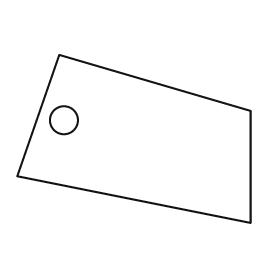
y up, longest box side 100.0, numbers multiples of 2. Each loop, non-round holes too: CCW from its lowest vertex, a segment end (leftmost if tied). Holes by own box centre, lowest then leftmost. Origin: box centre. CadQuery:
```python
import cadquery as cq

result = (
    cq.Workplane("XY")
    .moveTo(50.0, -36.0)
    .lineTo(50.0, 12.0)
    .lineTo(-32.0, 36.0)
    .lineTo(-50.0, -16.0)
    .close()
    .moveTo(-30.0, 8.0)
    .circle(6.0)
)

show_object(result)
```